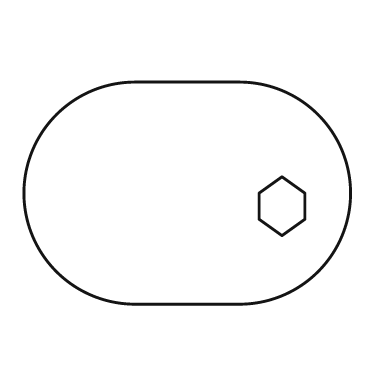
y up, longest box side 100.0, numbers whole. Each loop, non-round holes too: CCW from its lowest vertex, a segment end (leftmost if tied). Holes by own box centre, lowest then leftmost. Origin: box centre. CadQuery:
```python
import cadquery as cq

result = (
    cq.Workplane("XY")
    .moveTo(-16.0, -34.0)
    .lineTo(16.0, -34.0)
    .threePointArc((50.0, 0.0), (16.0, 34.0))
    .lineTo(-16.0, 34.0)
    .threePointArc((-50.0, 0.0), (-16.0, -34.0))
    .close()
    .moveTo(29.0, -13.0)
    .lineTo(36.0, -8.0)
    .lineTo(36.0, 0.0)
    .lineTo(29.0, 5.0)
    .lineTo(22.0, 0.0)
    .lineTo(22.0, -8.0)
    .close()
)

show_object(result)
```